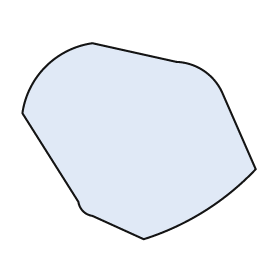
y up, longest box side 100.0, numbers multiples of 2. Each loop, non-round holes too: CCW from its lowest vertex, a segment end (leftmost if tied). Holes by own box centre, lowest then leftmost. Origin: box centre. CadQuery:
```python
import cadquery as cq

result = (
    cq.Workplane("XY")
    .moveTo(2.0, -42.0)
    .threePointArc((28.0, -30.0), (50.0, -12.0))
    .lineTo(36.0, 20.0)
    .threePointArc((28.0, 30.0), (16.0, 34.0))
    .lineTo(-20.0, 42.0)
    .threePointArc((-40.0, 32.0), (-50.0, 12.0))
    .lineTo(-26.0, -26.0)
    .threePointArc((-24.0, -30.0), (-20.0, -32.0))
    .close()
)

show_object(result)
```